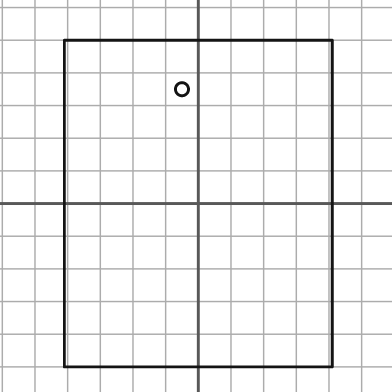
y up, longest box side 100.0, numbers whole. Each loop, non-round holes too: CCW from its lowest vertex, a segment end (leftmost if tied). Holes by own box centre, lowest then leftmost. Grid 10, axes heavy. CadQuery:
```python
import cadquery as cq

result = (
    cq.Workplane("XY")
    .moveTo(-41.0, -50.0)
    .lineTo(41.0, -50.0)
    .lineTo(41.0, 50.0)
    .lineTo(-41.0, 50.0)
    .close()
    .moveTo(-5.0, 35.0)
    .circle(2.0)
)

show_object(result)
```